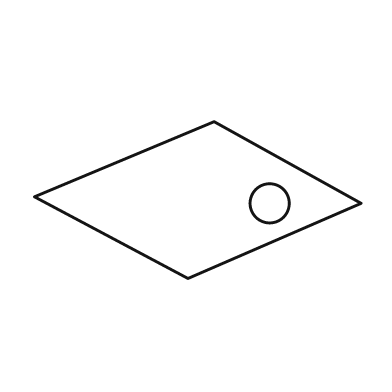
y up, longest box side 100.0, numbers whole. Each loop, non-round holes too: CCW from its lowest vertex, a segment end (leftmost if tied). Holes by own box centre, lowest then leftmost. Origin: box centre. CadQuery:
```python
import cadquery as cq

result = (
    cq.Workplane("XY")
    .moveTo(-3.0, -24.0)
    .lineTo(50.0, -1.0)
    .lineTo(5.0, 24.0)
    .lineTo(-50.0, 1.0)
    .close()
    .moveTo(22.0, -1.0)
    .circle(6.0)
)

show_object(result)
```